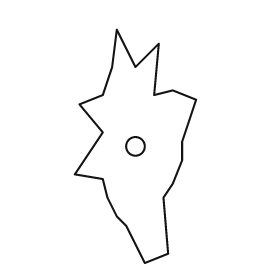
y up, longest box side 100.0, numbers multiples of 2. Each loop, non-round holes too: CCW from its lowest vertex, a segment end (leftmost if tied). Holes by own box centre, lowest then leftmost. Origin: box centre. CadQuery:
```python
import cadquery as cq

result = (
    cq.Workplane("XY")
    .moveTo(4.0, -50.0)
    .lineTo(14.0, -46.0)
    .lineTo(12.0, -22.0)
    .lineTo(16.0, -16.0)
    .lineTo(20.0, -6.0)
    .lineTo(20.0, 2.0)
    .lineTo(26.0, 20.0)
    .lineTo(16.0, 24.0)
    .lineTo(8.0, 22.0)
    .lineTo(10.0, 44.0)
    .lineTo(0.0, 34.0)
    .lineTo(-8.0, 50.0)
    .lineTo(-10.0, 34.0)
    .lineTo(-14.0, 22.0)
    .lineTo(-24.0, 18.0)
    .lineTo(-14.0, 6.0)
    .lineTo(-26.0, -12.0)
    .lineTo(-14.0, -14.0)
    .lineTo(-12.0, -22.0)
    .lineTo(-8.0, -30.0)
    .lineTo(-4.0, -34.0)
    .close()
    .moveTo(0.0, 0.0)
    .circle(4.0)
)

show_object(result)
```